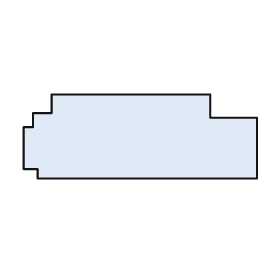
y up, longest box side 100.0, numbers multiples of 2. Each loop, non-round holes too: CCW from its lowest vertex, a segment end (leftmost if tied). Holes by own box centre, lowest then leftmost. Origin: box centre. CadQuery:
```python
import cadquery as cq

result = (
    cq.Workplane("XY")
    .moveTo(-44.0, -18.0)
    .lineTo(50.0, -18.0)
    .lineTo(50.0, 8.0)
    .lineTo(30.0, 8.0)
    .lineTo(30.0, 18.0)
    .lineTo(-38.0, 18.0)
    .lineTo(-38.0, 10.0)
    .lineTo(-46.0, 10.0)
    .lineTo(-46.0, 4.0)
    .lineTo(-50.0, 4.0)
    .lineTo(-50.0, -14.0)
    .lineTo(-44.0, -14.0)
    .close()
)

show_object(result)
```